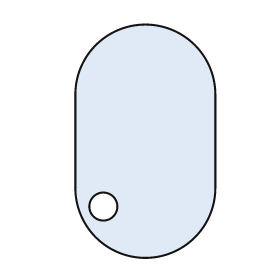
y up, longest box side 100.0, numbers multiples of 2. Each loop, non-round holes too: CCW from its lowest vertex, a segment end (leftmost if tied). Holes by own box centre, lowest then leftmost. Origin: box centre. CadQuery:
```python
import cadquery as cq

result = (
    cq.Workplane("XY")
    .moveTo(-30.0, -20.0)
    .threePointArc((0.0, -50.0), (30.0, -20.0))
    .lineTo(30.0, 20.0)
    .threePointArc((0.0, 50.0), (-30.0, 20.0))
    .close()
    .moveTo(-18.0, -28.0)
    .circle(6.0)
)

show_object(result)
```